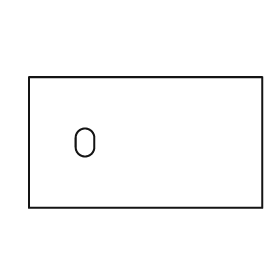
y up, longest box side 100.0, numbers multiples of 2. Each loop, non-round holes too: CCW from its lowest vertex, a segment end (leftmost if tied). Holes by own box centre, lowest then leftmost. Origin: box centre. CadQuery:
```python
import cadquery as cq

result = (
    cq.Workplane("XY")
    .moveTo(-50.0, -28.0)
    .lineTo(50.0, -28.0)
    .lineTo(50.0, 28.0)
    .lineTo(-50.0, 28.0)
    .close()
    .moveTo(-30.0, -2.0)
    .threePointArc((-26.0, -6.0), (-22.0, -2.0))
    .lineTo(-22.0, 2.0)
    .threePointArc((-26.0, 6.0), (-30.0, 2.0))
    .close()
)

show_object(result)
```